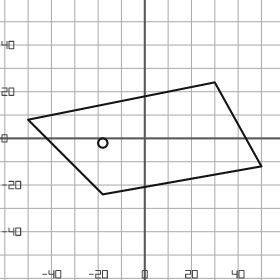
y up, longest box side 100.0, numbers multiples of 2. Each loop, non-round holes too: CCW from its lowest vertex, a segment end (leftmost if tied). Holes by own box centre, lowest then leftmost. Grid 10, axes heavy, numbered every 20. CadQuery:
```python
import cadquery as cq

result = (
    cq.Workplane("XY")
    .moveTo(-18.0, -24.0)
    .lineTo(50.0, -12.0)
    .lineTo(30.0, 24.0)
    .lineTo(-50.0, 8.0)
    .close()
    .moveTo(-18.0, -2.0)
    .circle(2.0)
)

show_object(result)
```